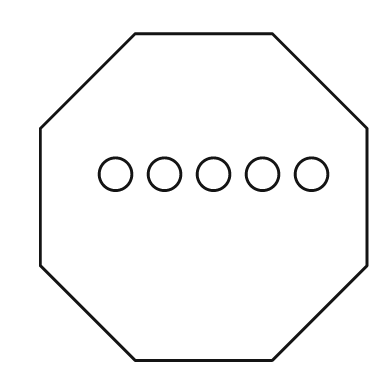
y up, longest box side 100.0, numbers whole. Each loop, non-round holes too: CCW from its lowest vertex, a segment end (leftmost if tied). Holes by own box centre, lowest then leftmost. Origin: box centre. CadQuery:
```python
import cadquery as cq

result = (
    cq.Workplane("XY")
    .moveTo(-21.0, -50.0)
    .lineTo(21.0, -50.0)
    .lineTo(50.0, -21.0)
    .lineTo(50.0, 21.0)
    .lineTo(21.0, 50.0)
    .lineTo(-21.0, 50.0)
    .lineTo(-50.0, 21.0)
    .lineTo(-50.0, -21.0)
    .close()
    .moveTo(-27.0, 7.0)
    .circle(5.0)
    .moveTo(-12.0, 7.0)
    .circle(5.0)
    .moveTo(3.0, 7.0)
    .circle(5.0)
    .moveTo(18.0, 7.0)
    .circle(5.0)
    .moveTo(33.0, 7.0)
    .circle(5.0)
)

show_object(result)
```